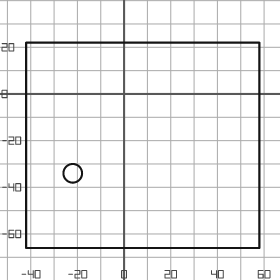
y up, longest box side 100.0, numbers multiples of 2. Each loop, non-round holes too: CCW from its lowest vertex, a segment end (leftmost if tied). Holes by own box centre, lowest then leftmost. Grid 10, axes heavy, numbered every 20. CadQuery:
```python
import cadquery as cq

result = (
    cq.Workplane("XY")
    .moveTo(-42.0, -66.0)
    .lineTo(58.0, -66.0)
    .lineTo(58.0, 22.0)
    .lineTo(-42.0, 22.0)
    .close()
    .moveTo(-22.0, -34.0)
    .circle(4.0)
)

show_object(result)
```